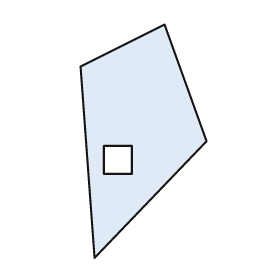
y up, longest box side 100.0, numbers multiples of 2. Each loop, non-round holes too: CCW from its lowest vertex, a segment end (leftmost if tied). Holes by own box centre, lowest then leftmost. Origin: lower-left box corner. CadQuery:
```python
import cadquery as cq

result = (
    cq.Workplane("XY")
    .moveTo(6.0, 0.0)
    .lineTo(54.0, 50.0)
    .lineTo(36.0, 100.0)
    .lineTo(0.0, 82.0)
    .close()
    .moveTo(10.0, 36.0)
    .lineTo(22.0, 36.0)
    .lineTo(22.0, 48.0)
    .lineTo(10.0, 48.0)
    .close()
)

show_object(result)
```